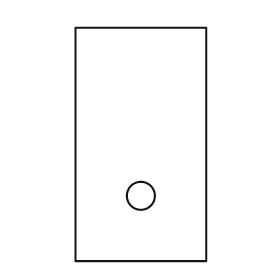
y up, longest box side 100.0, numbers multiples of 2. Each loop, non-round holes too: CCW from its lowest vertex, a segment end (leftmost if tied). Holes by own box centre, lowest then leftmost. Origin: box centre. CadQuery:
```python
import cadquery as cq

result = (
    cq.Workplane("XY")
    .moveTo(-28.0, -50.0)
    .lineTo(28.0, -50.0)
    .lineTo(28.0, 50.0)
    .lineTo(-28.0, 50.0)
    .close()
    .moveTo(0.0, -22.0)
    .circle(6.0)
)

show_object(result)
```